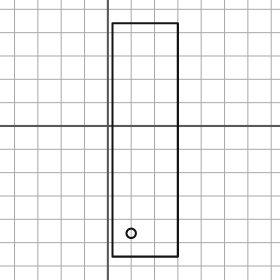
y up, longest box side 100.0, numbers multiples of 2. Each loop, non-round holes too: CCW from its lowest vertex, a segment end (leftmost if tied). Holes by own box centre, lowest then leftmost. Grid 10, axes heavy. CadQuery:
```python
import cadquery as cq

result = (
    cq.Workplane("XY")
    .moveTo(2.0, -56.0)
    .lineTo(30.0, -56.0)
    .lineTo(30.0, 44.0)
    .lineTo(2.0, 44.0)
    .close()
    .moveTo(10.0, -46.0)
    .circle(2.0)
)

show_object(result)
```